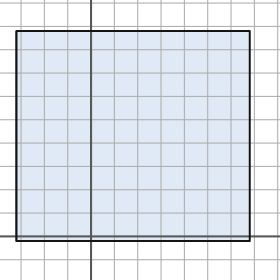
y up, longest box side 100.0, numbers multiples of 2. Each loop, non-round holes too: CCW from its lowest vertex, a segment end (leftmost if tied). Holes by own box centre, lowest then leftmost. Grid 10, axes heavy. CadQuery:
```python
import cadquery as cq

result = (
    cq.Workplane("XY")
    .moveTo(-32.0, -2.0)
    .lineTo(68.0, -2.0)
    .lineTo(68.0, 88.0)
    .lineTo(-32.0, 88.0)
    .close()
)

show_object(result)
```